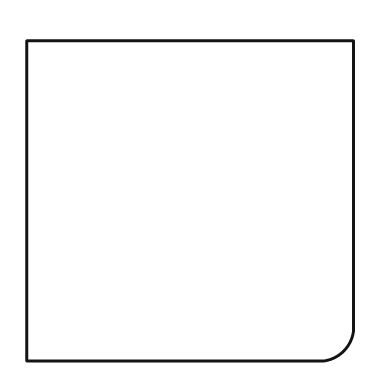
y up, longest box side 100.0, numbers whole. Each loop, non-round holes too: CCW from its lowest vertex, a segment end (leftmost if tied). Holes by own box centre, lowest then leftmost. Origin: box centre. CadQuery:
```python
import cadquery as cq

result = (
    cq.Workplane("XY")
    .moveTo(-50.0, -49.0)
    .lineTo(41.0, -49.0)
    .threePointArc((47.0, -46.0), (50.0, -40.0))
    .lineTo(50.0, 49.0)
    .lineTo(-50.0, 49.0)
    .close()
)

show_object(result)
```